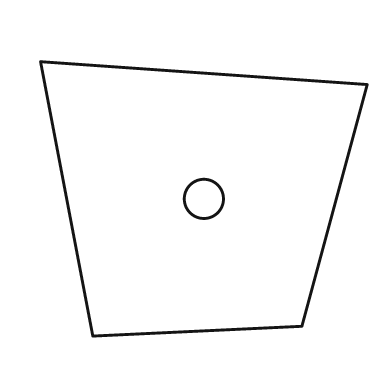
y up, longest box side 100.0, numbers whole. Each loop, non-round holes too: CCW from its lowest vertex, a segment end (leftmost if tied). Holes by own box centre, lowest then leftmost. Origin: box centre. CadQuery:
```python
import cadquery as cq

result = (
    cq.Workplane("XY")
    .moveTo(-34.0, -42.0)
    .lineTo(30.0, -39.0)
    .lineTo(50.0, 35.0)
    .lineTo(-50.0, 42.0)
    .close()
    .moveTo(0.0, 0.0)
    .circle(6.0)
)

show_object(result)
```